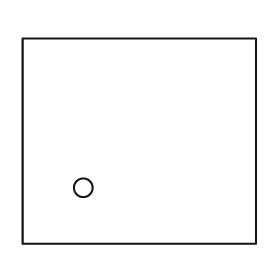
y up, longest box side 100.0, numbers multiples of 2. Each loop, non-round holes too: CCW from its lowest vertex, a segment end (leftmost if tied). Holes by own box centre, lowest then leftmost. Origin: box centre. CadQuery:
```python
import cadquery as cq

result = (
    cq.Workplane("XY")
    .moveTo(-50.0, -44.0)
    .lineTo(50.0, -44.0)
    .lineTo(50.0, 44.0)
    .lineTo(-50.0, 44.0)
    .close()
    .moveTo(-24.0, -20.0)
    .circle(4.0)
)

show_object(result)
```